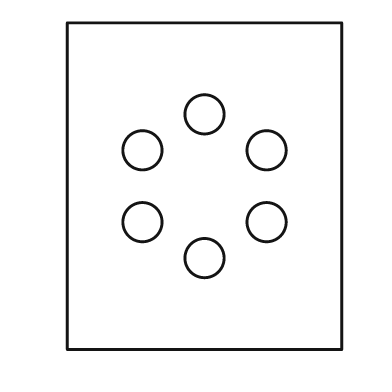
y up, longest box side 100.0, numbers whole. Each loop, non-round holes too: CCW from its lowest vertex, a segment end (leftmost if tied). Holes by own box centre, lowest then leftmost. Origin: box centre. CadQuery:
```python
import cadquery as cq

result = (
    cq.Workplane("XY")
    .moveTo(-42.0, -50.0)
    .lineTo(42.0, -50.0)
    .lineTo(42.0, 50.0)
    .lineTo(-42.0, 50.0)
    .close()
    .moveTo(0.0, -22.0)
    .circle(6.0)
    .moveTo(-19.0, -11.0)
    .circle(6.0)
    .moveTo(19.0, -11.0)
    .circle(6.0)
    .moveTo(-19.0, 11.0)
    .circle(6.0)
    .moveTo(19.0, 11.0)
    .circle(6.0)
    .moveTo(0.0, 22.0)
    .circle(6.0)
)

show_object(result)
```